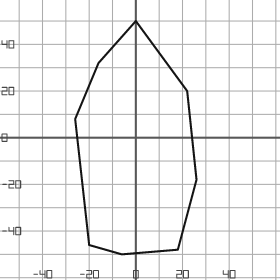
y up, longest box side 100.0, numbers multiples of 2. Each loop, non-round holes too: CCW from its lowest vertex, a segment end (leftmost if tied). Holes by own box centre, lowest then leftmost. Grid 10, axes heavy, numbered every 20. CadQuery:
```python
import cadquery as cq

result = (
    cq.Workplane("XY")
    .moveTo(-6.0, -50.0)
    .lineTo(18.0, -48.0)
    .lineTo(26.0, -18.0)
    .lineTo(22.0, 20.0)
    .lineTo(0.0, 50.0)
    .lineTo(-16.0, 32.0)
    .lineTo(-26.0, 8.0)
    .lineTo(-20.0, -46.0)
    .close()
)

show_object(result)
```